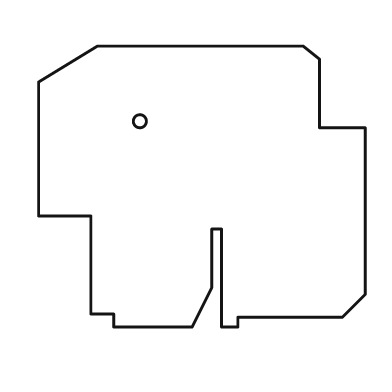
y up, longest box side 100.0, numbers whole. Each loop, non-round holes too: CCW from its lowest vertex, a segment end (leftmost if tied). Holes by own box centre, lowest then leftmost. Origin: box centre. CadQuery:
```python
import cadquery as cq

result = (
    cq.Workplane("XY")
    .moveTo(-27.0, -43.0)
    .lineTo(-3.0, -43.0)
    .lineTo(3.0, -31.0)
    .lineTo(3.0, -13.0)
    .lineTo(6.0, -13.0)
    .lineTo(6.0, -43.0)
    .lineTo(11.0, -43.0)
    .lineTo(11.0, -40.0)
    .lineTo(43.0, -40.0)
    .lineTo(50.0, -33.0)
    .lineTo(50.0, 18.0)
    .lineTo(36.0, 18.0)
    .lineTo(36.0, 39.0)
    .lineTo(31.0, 43.0)
    .lineTo(-32.0, 43.0)
    .lineTo(-50.0, 32.0)
    .lineTo(-50.0, -9.0)
    .lineTo(-34.0, -9.0)
    .lineTo(-34.0, -39.0)
    .lineTo(-27.0, -39.0)
    .close()
    .moveTo(-19.0, 20.0)
    .circle(2.0)
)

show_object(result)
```